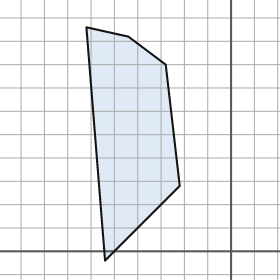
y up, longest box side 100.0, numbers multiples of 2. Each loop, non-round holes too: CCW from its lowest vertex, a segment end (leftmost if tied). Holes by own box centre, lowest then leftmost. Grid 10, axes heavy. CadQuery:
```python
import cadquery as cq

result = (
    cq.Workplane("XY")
    .moveTo(-54.0, -4.0)
    .lineTo(-22.0, 28.0)
    .lineTo(-28.0, 80.0)
    .lineTo(-44.0, 92.0)
    .lineTo(-62.0, 96.0)
    .close()
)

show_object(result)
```